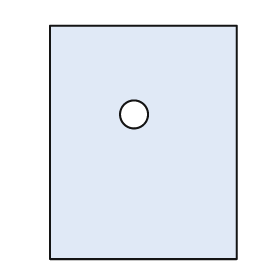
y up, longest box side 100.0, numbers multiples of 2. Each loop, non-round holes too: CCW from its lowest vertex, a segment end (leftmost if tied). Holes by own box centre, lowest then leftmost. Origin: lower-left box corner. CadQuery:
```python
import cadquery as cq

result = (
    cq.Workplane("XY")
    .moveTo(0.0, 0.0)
    .lineTo(80.0, 0.0)
    .lineTo(80.0, 100.0)
    .lineTo(0.0, 100.0)
    .close()
    .moveTo(36.0, 62.0)
    .circle(6.0)
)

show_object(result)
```